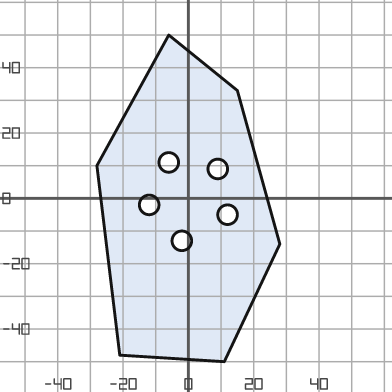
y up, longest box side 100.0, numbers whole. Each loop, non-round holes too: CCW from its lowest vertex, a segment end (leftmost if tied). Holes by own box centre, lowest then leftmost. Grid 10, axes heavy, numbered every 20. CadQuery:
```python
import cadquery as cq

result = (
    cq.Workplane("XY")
    .moveTo(11.0, -50.0)
    .lineTo(28.0, -14.0)
    .lineTo(15.0, 33.0)
    .lineTo(-6.0, 50.0)
    .lineTo(-28.0, 10.0)
    .lineTo(-21.0, -48.0)
    .close()
    .moveTo(-2.0, -13.0)
    .circle(3.0)
    .moveTo(12.0, -5.0)
    .circle(3.0)
    .moveTo(-12.0, -2.0)
    .circle(3.0)
    .moveTo(9.0, 9.0)
    .circle(3.0)
    .moveTo(-6.0, 11.0)
    .circle(3.0)
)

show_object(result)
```